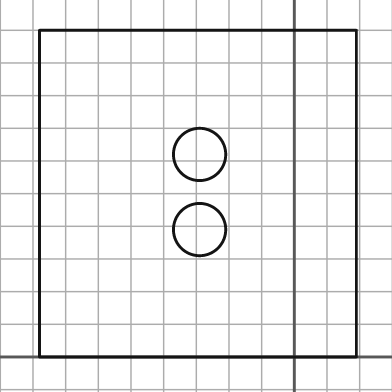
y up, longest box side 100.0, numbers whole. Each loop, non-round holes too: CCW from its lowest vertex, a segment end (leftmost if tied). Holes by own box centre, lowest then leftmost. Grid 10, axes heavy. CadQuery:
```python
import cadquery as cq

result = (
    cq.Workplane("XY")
    .moveTo(-78.0, 0.0)
    .lineTo(19.0, 0.0)
    .lineTo(19.0, 100.0)
    .lineTo(-78.0, 100.0)
    .close()
    .moveTo(-29.0, 39.0)
    .circle(8.0)
    .moveTo(-29.0, 62.0)
    .circle(8.0)
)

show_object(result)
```